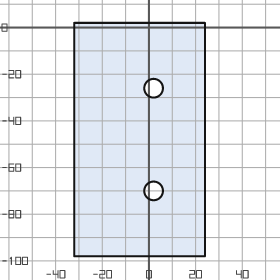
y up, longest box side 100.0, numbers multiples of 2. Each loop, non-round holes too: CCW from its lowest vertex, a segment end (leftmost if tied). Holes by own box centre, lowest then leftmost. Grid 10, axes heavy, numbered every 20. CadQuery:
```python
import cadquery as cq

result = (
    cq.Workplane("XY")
    .moveTo(-32.0, -98.0)
    .lineTo(24.0, -98.0)
    .lineTo(24.0, 2.0)
    .lineTo(-32.0, 2.0)
    .close()
    .moveTo(2.0, -70.0)
    .circle(4.0)
    .moveTo(2.0, -26.0)
    .circle(4.0)
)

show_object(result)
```